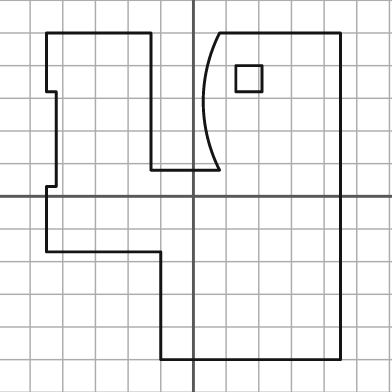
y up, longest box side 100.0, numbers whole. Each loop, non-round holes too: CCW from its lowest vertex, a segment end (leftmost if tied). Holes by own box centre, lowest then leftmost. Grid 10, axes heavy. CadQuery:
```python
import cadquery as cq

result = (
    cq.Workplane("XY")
    .moveTo(-10.0, -50.0)
    .lineTo(45.0, -50.0)
    .lineTo(45.0, 50.0)
    .lineTo(8.0, 50.0)
    .threePointArc((3.0, 29.0), (8.0, 8.0))
    .lineTo(-13.0, 8.0)
    .lineTo(-13.0, 50.0)
    .lineTo(-45.0, 50.0)
    .lineTo(-45.0, 32.0)
    .lineTo(-42.0, 32.0)
    .lineTo(-42.0, 3.0)
    .lineTo(-45.0, 3.0)
    .lineTo(-45.0, -17.0)
    .lineTo(-10.0, -17.0)
    .close()
    .moveTo(13.0, 32.0)
    .lineTo(21.0, 32.0)
    .lineTo(21.0, 40.0)
    .lineTo(13.0, 40.0)
    .close()
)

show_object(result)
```